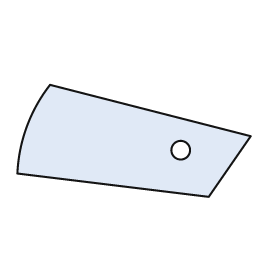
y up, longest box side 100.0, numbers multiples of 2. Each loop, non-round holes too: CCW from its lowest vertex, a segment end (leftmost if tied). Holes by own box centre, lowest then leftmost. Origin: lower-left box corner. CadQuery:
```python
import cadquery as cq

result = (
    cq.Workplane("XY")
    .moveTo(82.0, 0.0)
    .lineTo(100.0, 26.0)
    .lineTo(14.0, 48.0)
    .threePointArc((4.0, 30.0), (0.0, 10.0))
    .close()
    .moveTo(70.0, 20.0)
    .circle(4.0)
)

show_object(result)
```